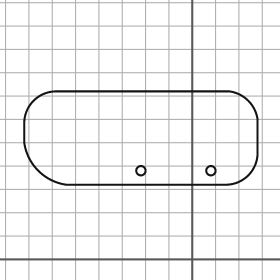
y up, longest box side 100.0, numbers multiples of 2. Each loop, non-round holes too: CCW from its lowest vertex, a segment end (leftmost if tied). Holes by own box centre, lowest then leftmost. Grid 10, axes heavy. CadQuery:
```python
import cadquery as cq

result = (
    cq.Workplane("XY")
    .moveTo(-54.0, 32.0)
    .lineTo(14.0, 32.0)
    .threePointArc((24.0, 36.0), (28.0, 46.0))
    .lineTo(28.0, 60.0)
    .threePointArc((24.0, 68.0), (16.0, 72.0))
    .lineTo(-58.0, 72.0)
    .threePointArc((-68.0, 68.0), (-72.0, 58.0))
    .lineTo(-72.0, 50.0)
    .threePointArc((-66.0, 38.0), (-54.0, 32.0))
    .close()
    .moveTo(-22.0, 38.0)
    .circle(2.0)
    .moveTo(8.0, 38.0)
    .circle(2.0)
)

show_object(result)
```